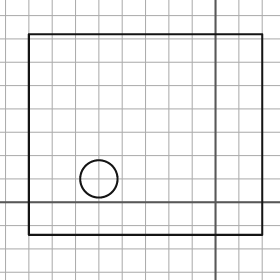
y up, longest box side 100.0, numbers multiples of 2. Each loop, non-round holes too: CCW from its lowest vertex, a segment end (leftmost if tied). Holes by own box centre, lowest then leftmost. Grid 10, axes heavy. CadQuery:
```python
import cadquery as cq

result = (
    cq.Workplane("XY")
    .moveTo(-80.0, -14.0)
    .lineTo(20.0, -14.0)
    .lineTo(20.0, 72.0)
    .lineTo(-80.0, 72.0)
    .close()
    .moveTo(-50.0, 10.0)
    .circle(8.0)
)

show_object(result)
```